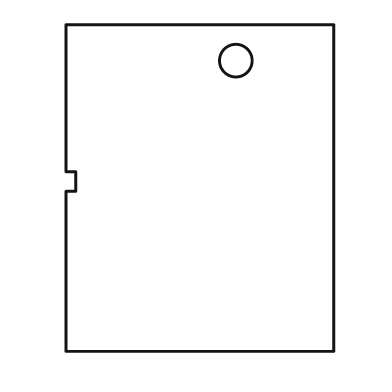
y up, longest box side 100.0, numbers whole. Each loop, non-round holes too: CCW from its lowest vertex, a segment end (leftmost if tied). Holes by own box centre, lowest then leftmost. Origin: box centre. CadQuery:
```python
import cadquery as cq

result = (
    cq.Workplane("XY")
    .moveTo(-41.0, -50.0)
    .lineTo(41.0, -50.0)
    .lineTo(41.0, 50.0)
    .lineTo(-41.0, 50.0)
    .lineTo(-41.0, 5.0)
    .lineTo(-38.0, 5.0)
    .lineTo(-38.0, -1.0)
    .lineTo(-41.0, -1.0)
    .close()
    .moveTo(11.0, 39.0)
    .circle(5.0)
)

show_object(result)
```